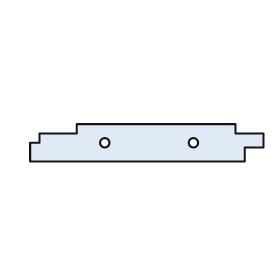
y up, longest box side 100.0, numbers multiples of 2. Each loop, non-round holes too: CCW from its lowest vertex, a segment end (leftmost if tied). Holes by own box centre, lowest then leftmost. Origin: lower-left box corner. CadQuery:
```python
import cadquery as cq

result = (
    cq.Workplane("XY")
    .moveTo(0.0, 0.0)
    .lineTo(92.0, 0.0)
    .lineTo(92.0, 6.0)
    .lineTo(100.0, 6.0)
    .lineTo(100.0, 12.0)
    .lineTo(88.0, 12.0)
    .lineTo(88.0, 16.0)
    .lineTo(20.0, 16.0)
    .lineTo(20.0, 12.0)
    .lineTo(4.0, 12.0)
    .lineTo(4.0, 8.0)
    .lineTo(0.0, 8.0)
    .close()
    .moveTo(32.0, 8.0)
    .circle(2.0)
    .moveTo(70.0, 8.0)
    .circle(2.0)
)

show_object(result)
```